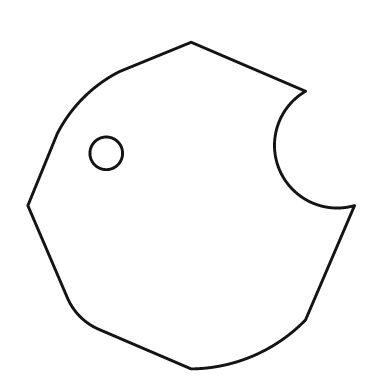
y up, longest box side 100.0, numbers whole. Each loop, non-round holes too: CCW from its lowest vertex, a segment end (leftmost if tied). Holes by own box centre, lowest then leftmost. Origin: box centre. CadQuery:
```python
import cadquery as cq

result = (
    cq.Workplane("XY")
    .moveTo(0.0, -50.0)
    .threePointArc((19.0, -46.0), (35.0, -35.0))
    .lineTo(50.0, 0.0)
    .threePointArc((27.0, 11.0), (35.0, 35.0))
    .lineTo(0.0, 50.0)
    .lineTo(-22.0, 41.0)
    .threePointArc((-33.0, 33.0), (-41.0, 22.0))
    .lineTo(-50.0, 0.0)
    .lineTo(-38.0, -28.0)
    .threePointArc((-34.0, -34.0), (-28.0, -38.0))
    .close()
    .moveTo(-26.0, 16.0)
    .circle(5.0)
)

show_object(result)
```